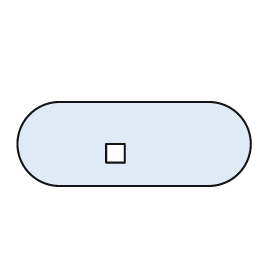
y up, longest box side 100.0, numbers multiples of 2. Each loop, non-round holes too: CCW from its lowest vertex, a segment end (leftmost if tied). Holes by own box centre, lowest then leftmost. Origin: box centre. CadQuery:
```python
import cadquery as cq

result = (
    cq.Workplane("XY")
    .moveTo(-32.0, -18.0)
    .lineTo(32.0, -18.0)
    .threePointArc((50.0, 0.0), (32.0, 18.0))
    .lineTo(-32.0, 18.0)
    .threePointArc((-50.0, 0.0), (-32.0, -18.0))
    .close()
    .moveTo(-12.0, -8.0)
    .lineTo(-4.0, -8.0)
    .lineTo(-4.0, 0.0)
    .lineTo(-12.0, 0.0)
    .close()
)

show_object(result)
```